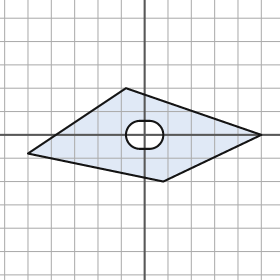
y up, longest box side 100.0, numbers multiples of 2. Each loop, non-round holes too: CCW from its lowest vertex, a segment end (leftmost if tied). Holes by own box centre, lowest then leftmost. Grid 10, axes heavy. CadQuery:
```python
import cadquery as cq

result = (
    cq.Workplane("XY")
    .moveTo(8.0, -20.0)
    .lineTo(50.0, 0.0)
    .lineTo(-8.0, 20.0)
    .lineTo(-50.0, -8.0)
    .close()
    .moveTo(-2.0, -6.0)
    .lineTo(2.0, -6.0)
    .threePointArc((8.0, 0.0), (2.0, 6.0))
    .lineTo(-2.0, 6.0)
    .threePointArc((-8.0, 0.0), (-2.0, -6.0))
    .close()
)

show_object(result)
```